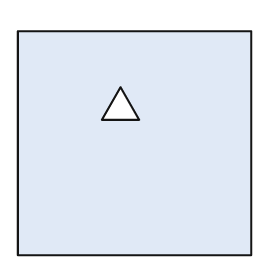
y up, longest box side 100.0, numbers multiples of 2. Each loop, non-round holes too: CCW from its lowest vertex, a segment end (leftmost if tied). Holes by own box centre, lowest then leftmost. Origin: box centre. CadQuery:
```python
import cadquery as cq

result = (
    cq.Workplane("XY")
    .moveTo(-50.0, -48.0)
    .lineTo(50.0, -48.0)
    .lineTo(50.0, 48.0)
    .lineTo(-50.0, 48.0)
    .close()
    .moveTo(-14.0, 10.0)
    .lineTo(2.0, 10.0)
    .lineTo(-6.0, 24.0)
    .close()
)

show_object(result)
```